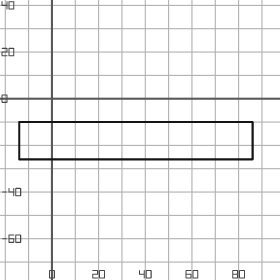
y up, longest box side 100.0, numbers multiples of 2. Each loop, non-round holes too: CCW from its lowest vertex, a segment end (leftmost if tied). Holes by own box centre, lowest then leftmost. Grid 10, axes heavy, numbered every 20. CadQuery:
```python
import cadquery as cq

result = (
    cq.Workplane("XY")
    .moveTo(-14.0, -26.0)
    .lineTo(86.0, -26.0)
    .lineTo(86.0, -10.0)
    .lineTo(-14.0, -10.0)
    .close()
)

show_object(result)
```